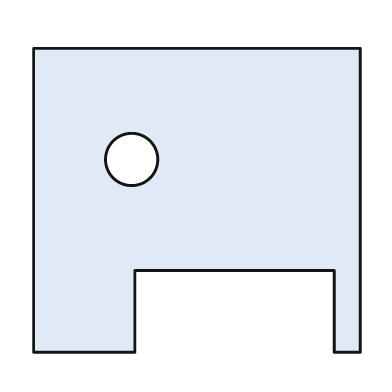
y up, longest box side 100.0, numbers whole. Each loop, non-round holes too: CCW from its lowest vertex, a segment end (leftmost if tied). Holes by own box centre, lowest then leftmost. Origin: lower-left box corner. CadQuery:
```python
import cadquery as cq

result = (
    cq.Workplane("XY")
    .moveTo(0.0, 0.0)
    .lineTo(31.0, 0.0)
    .lineTo(31.0, 25.0)
    .lineTo(92.0, 25.0)
    .lineTo(92.0, 0.0)
    .lineTo(100.0, 0.0)
    .lineTo(100.0, 93.0)
    .lineTo(0.0, 93.0)
    .close()
    .moveTo(30.0, 59.0)
    .circle(8.0)
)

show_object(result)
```